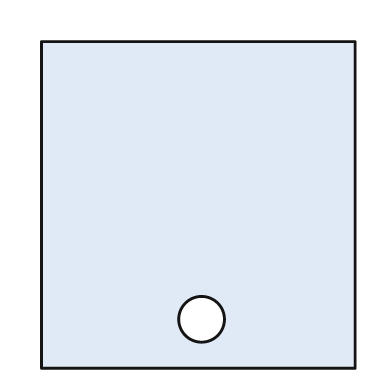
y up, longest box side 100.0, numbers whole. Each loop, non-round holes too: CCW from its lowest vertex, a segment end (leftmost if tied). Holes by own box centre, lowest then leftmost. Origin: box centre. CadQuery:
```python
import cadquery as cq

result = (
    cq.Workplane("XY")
    .moveTo(-48.0, -50.0)
    .lineTo(48.0, -50.0)
    .lineTo(48.0, 50.0)
    .lineTo(-48.0, 50.0)
    .close()
    .moveTo(1.0, -35.0)
    .circle(7.0)
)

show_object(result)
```